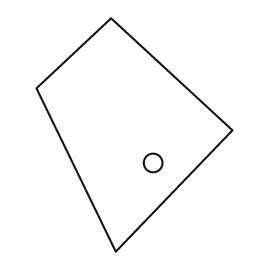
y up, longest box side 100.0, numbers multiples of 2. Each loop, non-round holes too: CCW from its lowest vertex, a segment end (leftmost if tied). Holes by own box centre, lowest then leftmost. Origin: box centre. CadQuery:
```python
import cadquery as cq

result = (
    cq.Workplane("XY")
    .moveTo(-8.0, -50.0)
    .lineTo(42.0, 2.0)
    .lineTo(-10.0, 50.0)
    .lineTo(-42.0, 20.0)
    .close()
    .moveTo(8.0, -12.0)
    .circle(4.0)
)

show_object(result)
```